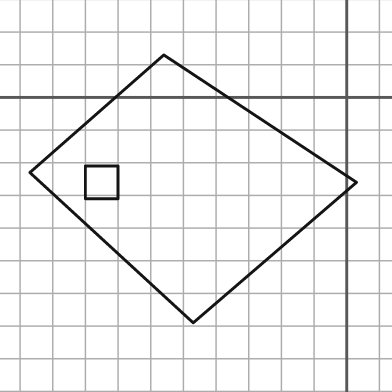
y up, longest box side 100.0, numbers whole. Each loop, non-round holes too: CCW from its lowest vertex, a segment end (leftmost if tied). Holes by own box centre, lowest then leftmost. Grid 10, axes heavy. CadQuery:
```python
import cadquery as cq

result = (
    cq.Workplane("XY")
    .moveTo(-47.0, -69.0)
    .lineTo(3.0, -26.0)
    .lineTo(-56.0, 13.0)
    .lineTo(-97.0, -23.0)
    .close()
    .moveTo(-80.0, -31.0)
    .lineTo(-70.0, -31.0)
    .lineTo(-70.0, -21.0)
    .lineTo(-80.0, -21.0)
    .close()
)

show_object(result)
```